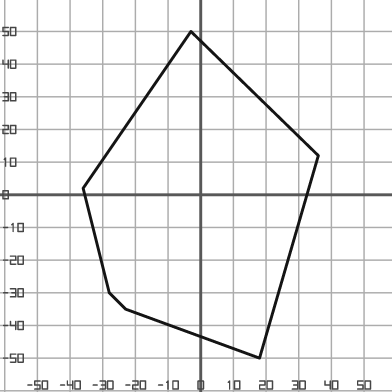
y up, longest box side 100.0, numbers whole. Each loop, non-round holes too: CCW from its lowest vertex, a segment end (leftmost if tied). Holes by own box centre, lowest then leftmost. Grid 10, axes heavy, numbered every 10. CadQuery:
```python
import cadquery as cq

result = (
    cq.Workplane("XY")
    .moveTo(18.0, -50.0)
    .lineTo(36.0, 12.0)
    .lineTo(-3.0, 50.0)
    .lineTo(-36.0, 2.0)
    .lineTo(-28.0, -30.0)
    .lineTo(-23.0, -35.0)
    .close()
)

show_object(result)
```